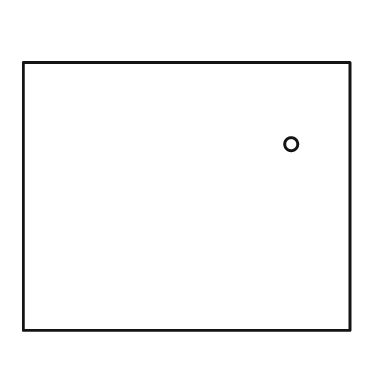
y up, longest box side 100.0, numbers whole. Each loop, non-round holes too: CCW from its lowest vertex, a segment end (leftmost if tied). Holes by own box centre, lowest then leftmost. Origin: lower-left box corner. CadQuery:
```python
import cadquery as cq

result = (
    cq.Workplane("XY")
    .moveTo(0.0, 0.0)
    .lineTo(100.0, 0.0)
    .lineTo(100.0, 82.0)
    .lineTo(0.0, 82.0)
    .close()
    .moveTo(82.0, 57.0)
    .circle(2.0)
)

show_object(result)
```